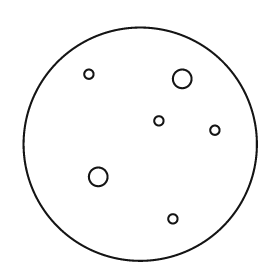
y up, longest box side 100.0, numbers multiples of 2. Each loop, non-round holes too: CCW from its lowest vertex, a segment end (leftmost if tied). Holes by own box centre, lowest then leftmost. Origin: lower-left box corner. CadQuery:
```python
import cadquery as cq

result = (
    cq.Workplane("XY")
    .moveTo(50.0, 50.0)
    .circle(50.0)
    .moveTo(64.0, 18.0)
    .circle(2.0)
    .moveTo(32.0, 36.0)
    .circle(4.0)
    .moveTo(82.0, 56.0)
    .circle(2.0)
    .moveTo(58.0, 60.0)
    .circle(2.0)
    .moveTo(68.0, 78.0)
    .circle(4.0)
    .moveTo(28.0, 80.0)
    .circle(2.0)
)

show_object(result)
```